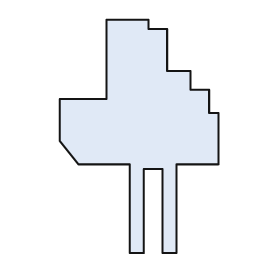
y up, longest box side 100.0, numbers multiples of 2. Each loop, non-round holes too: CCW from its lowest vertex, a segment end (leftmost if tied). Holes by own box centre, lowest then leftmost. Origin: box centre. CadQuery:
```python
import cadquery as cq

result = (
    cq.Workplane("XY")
    .moveTo(-4.0, -50.0)
    .lineTo(2.0, -50.0)
    .lineTo(2.0, -14.0)
    .lineTo(10.0, -14.0)
    .lineTo(10.0, -50.0)
    .lineTo(16.0, -50.0)
    .lineTo(16.0, -12.0)
    .lineTo(34.0, -12.0)
    .lineTo(34.0, 10.0)
    .lineTo(30.0, 10.0)
    .lineTo(30.0, 20.0)
    .lineTo(22.0, 20.0)
    .lineTo(22.0, 28.0)
    .lineTo(12.0, 28.0)
    .lineTo(12.0, 46.0)
    .lineTo(4.0, 46.0)
    .lineTo(4.0, 50.0)
    .lineTo(-14.0, 50.0)
    .lineTo(-14.0, 16.0)
    .lineTo(-34.0, 16.0)
    .lineTo(-34.0, -2.0)
    .lineTo(-26.0, -12.0)
    .lineTo(-4.0, -12.0)
    .close()
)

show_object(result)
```